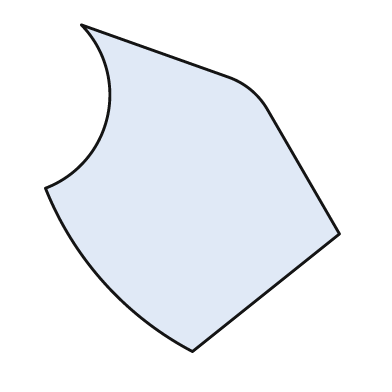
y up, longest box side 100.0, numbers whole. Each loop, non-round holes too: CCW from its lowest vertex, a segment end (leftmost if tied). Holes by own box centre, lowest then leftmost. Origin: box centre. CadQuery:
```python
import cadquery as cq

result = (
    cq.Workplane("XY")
    .moveTo(0.0, -50.0)
    .lineTo(45.0, -14.0)
    .lineTo(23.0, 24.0)
    .threePointArc((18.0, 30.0), (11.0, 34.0))
    .lineTo(-34.0, 50.0)
    .threePointArc((-26.0, 22.0), (-45.0, 0.0))
    .threePointArc((-27.0, -29.0), (0.0, -50.0))
    .close()
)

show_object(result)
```